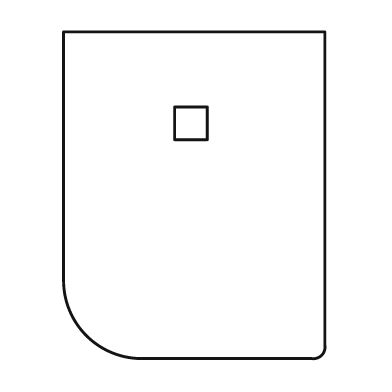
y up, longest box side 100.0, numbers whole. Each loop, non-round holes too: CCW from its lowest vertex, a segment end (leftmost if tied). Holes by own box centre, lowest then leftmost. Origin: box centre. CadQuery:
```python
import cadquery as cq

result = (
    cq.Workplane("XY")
    .moveTo(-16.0, -50.0)
    .lineTo(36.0, -50.0)
    .threePointArc((39.0, -49.0), (40.0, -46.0))
    .lineTo(40.0, 50.0)
    .lineTo(-40.0, 50.0)
    .lineTo(-40.0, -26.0)
    .threePointArc((-33.0, -43.0), (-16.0, -50.0))
    .close()
    .moveTo(-6.0, 17.0)
    .lineTo(4.0, 17.0)
    .lineTo(4.0, 27.0)
    .lineTo(-6.0, 27.0)
    .close()
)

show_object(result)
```